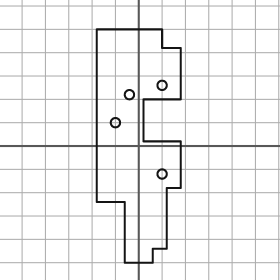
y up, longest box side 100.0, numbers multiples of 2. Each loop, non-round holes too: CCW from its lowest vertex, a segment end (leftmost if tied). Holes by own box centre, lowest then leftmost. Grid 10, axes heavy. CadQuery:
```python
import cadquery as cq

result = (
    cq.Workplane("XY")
    .moveTo(-6.0, -50.0)
    .lineTo(6.0, -50.0)
    .lineTo(6.0, -44.0)
    .lineTo(12.0, -44.0)
    .lineTo(12.0, -18.0)
    .lineTo(18.0, -18.0)
    .lineTo(18.0, 2.0)
    .lineTo(2.0, 2.0)
    .lineTo(2.0, 20.0)
    .lineTo(18.0, 20.0)
    .lineTo(18.0, 42.0)
    .lineTo(10.0, 42.0)
    .lineTo(10.0, 50.0)
    .lineTo(-18.0, 50.0)
    .lineTo(-18.0, -24.0)
    .lineTo(-6.0, -24.0)
    .close()
    .moveTo(10.0, -12.0)
    .circle(2.0)
    .moveTo(-10.0, 10.0)
    .circle(2.0)
    .moveTo(-4.0, 22.0)
    .circle(2.0)
    .moveTo(10.0, 26.0)
    .circle(2.0)
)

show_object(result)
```